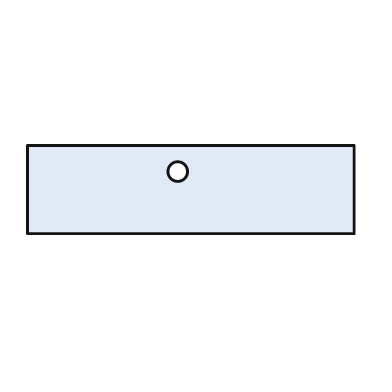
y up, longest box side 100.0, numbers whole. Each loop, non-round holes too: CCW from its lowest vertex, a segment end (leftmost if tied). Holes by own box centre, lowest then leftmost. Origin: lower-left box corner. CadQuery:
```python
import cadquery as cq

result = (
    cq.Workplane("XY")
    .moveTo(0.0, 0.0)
    .lineTo(100.0, 0.0)
    .lineTo(100.0, 27.0)
    .lineTo(0.0, 27.0)
    .close()
    .moveTo(46.0, 19.0)
    .circle(3.0)
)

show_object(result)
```